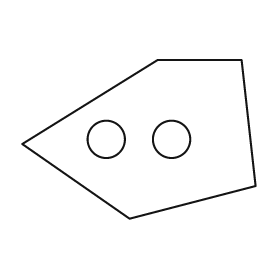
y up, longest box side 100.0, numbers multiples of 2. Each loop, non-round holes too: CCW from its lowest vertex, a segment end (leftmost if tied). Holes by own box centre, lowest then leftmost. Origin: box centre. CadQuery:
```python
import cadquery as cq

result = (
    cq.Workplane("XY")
    .moveTo(-4.0, -34.0)
    .lineTo(50.0, -20.0)
    .lineTo(44.0, 34.0)
    .lineTo(8.0, 34.0)
    .lineTo(-50.0, -2.0)
    .close()
    .moveTo(-14.0, 0.0)
    .circle(8.0)
    .moveTo(14.0, 0.0)
    .circle(8.0)
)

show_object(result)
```